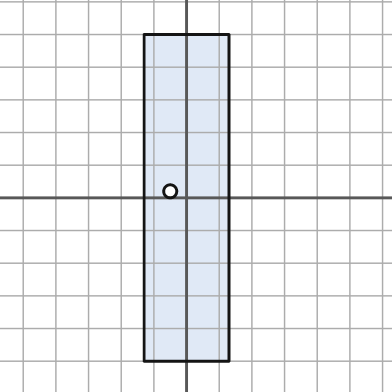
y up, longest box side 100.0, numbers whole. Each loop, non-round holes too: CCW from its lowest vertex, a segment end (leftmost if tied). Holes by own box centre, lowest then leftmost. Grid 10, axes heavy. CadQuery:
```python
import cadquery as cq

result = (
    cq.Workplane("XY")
    .moveTo(-13.0, -50.0)
    .lineTo(13.0, -50.0)
    .lineTo(13.0, 50.0)
    .lineTo(-13.0, 50.0)
    .close()
    .moveTo(-5.0, 2.0)
    .circle(2.0)
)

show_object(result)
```